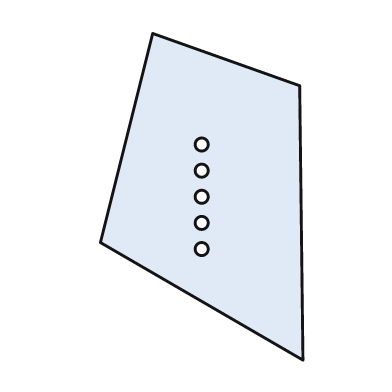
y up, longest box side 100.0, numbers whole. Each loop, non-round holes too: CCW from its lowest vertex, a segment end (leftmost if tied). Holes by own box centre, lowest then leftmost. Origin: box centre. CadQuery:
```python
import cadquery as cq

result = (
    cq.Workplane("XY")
    .moveTo(31.0, -50.0)
    .lineTo(30.0, 34.0)
    .lineTo(-15.0, 50.0)
    .lineTo(-31.0, -14.0)
    .close()
    .moveTo(0.0, -16.0)
    .circle(2.0)
    .moveTo(0.0, -8.0)
    .circle(2.0)
    .moveTo(0.0, 0.0)
    .circle(2.0)
    .moveTo(0.0, 8.0)
    .circle(2.0)
    .moveTo(0.0, 16.0)
    .circle(2.0)
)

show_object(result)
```